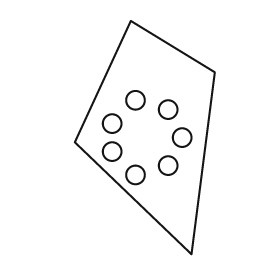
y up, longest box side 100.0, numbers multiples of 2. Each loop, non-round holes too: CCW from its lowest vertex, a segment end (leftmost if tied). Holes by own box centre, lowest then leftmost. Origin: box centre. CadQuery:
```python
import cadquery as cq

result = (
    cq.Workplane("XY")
    .moveTo(20.0, -50.0)
    .lineTo(30.0, 28.0)
    .lineTo(-6.0, 50.0)
    .lineTo(-30.0, -2.0)
    .close()
    .moveTo(-4.0, -16.0)
    .circle(4.0)
    .moveTo(10.0, -12.0)
    .circle(4.0)
    .moveTo(-14.0, -6.0)
    .circle(4.0)
    .moveTo(16.0, 0.0)
    .circle(4.0)
    .moveTo(-14.0, 6.0)
    .circle(4.0)
    .moveTo(10.0, 12.0)
    .circle(4.0)
    .moveTo(-4.0, 16.0)
    .circle(4.0)
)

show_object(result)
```